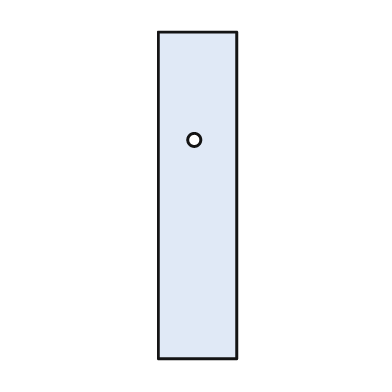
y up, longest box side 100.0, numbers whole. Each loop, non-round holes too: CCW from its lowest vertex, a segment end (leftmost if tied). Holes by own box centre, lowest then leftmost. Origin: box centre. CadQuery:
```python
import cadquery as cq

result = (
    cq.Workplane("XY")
    .moveTo(-12.0, -50.0)
    .lineTo(12.0, -50.0)
    .lineTo(12.0, 50.0)
    .lineTo(-12.0, 50.0)
    .close()
    .moveTo(-1.0, 17.0)
    .circle(2.0)
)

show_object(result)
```